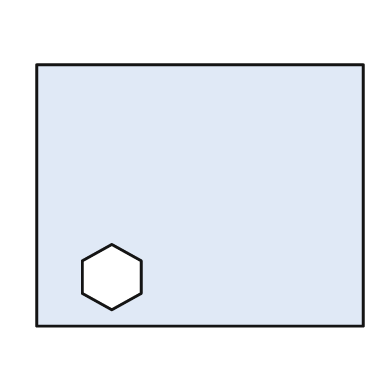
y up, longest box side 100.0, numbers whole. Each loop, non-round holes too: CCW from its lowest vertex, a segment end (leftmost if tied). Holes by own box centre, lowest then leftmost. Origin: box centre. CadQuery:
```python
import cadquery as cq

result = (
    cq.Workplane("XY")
    .moveTo(-50.0, -40.0)
    .lineTo(50.0, -40.0)
    .lineTo(50.0, 40.0)
    .lineTo(-50.0, 40.0)
    .close()
    .moveTo(-27.0, -35.0)
    .lineTo(-18.0, -30.0)
    .lineTo(-18.0, -20.0)
    .lineTo(-27.0, -15.0)
    .lineTo(-36.0, -20.0)
    .lineTo(-36.0, -30.0)
    .close()
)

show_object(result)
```